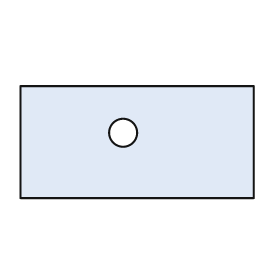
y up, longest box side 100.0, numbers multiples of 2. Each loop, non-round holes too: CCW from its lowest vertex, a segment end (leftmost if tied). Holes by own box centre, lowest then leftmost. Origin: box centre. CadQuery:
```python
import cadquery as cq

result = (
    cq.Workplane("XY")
    .moveTo(-50.0, -24.0)
    .lineTo(50.0, -24.0)
    .lineTo(50.0, 24.0)
    .lineTo(-50.0, 24.0)
    .close()
    .moveTo(-6.0, 4.0)
    .circle(6.0)
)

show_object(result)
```